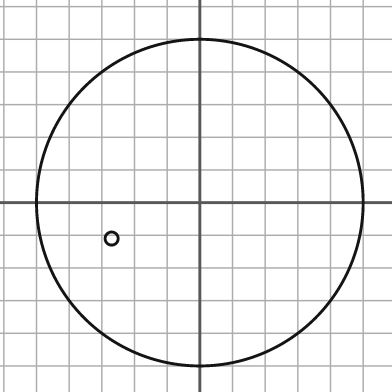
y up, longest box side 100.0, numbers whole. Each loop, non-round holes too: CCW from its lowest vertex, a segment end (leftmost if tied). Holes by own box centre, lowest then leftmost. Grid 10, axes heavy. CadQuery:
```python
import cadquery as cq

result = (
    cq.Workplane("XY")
    .moveTo(0.0, 0.0)
    .circle(50.0)
    .moveTo(-27.0, -11.0)
    .circle(2.0)
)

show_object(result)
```